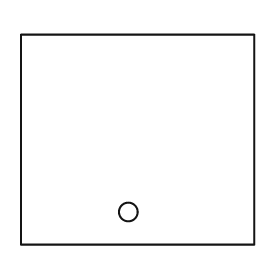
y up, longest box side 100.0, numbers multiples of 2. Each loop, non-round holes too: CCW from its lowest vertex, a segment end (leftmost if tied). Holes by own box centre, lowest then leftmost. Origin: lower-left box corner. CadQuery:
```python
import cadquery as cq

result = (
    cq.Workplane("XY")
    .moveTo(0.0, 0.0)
    .lineTo(100.0, 0.0)
    .lineTo(100.0, 90.0)
    .lineTo(0.0, 90.0)
    .close()
    .moveTo(46.0, 14.0)
    .circle(4.0)
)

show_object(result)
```